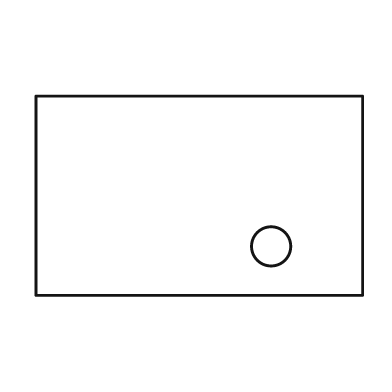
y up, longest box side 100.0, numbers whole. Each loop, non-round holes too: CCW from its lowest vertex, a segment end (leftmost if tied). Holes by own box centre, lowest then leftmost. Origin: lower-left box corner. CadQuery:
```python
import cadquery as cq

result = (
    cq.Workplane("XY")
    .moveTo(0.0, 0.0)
    .lineTo(100.0, 0.0)
    .lineTo(100.0, 61.0)
    .lineTo(0.0, 61.0)
    .close()
    .moveTo(72.0, 15.0)
    .circle(6.0)
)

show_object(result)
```